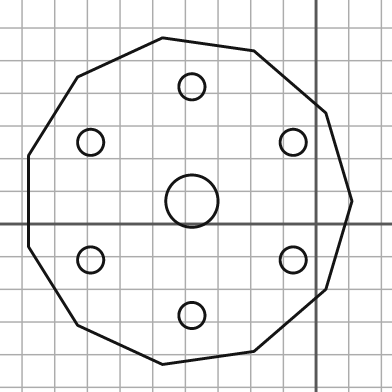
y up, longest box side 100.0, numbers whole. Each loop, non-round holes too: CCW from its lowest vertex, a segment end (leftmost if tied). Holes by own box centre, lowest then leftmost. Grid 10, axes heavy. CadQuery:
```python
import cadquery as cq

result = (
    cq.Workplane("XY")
    .moveTo(-47.0, -43.0)
    .lineTo(-19.0, -39.0)
    .lineTo(3.0, -20.0)
    .lineTo(11.0, 7.0)
    .lineTo(3.0, 34.0)
    .lineTo(-19.0, 53.0)
    .lineTo(-47.0, 57.0)
    .lineTo(-73.0, 45.0)
    .lineTo(-88.0, 21.0)
    .lineTo(-88.0, -7.0)
    .lineTo(-73.0, -31.0)
    .close()
    .moveTo(-38.0, -28.0)
    .circle(4.0)
    .moveTo(-69.0, -11.0)
    .circle(4.0)
    .moveTo(-7.0, -11.0)
    .circle(4.0)
    .moveTo(-38.0, 7.0)
    .circle(8.0)
    .moveTo(-69.0, 25.0)
    .circle(4.0)
    .moveTo(-7.0, 25.0)
    .circle(4.0)
    .moveTo(-38.0, 42.0)
    .circle(4.0)
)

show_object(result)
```